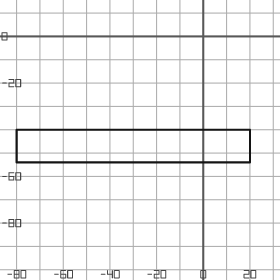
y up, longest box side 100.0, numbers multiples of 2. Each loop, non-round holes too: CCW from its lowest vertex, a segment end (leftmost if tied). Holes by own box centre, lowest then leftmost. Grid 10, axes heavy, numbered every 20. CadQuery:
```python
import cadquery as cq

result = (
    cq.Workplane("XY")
    .moveTo(-80.0, -54.0)
    .lineTo(20.0, -54.0)
    .lineTo(20.0, -40.0)
    .lineTo(-80.0, -40.0)
    .close()
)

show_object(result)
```